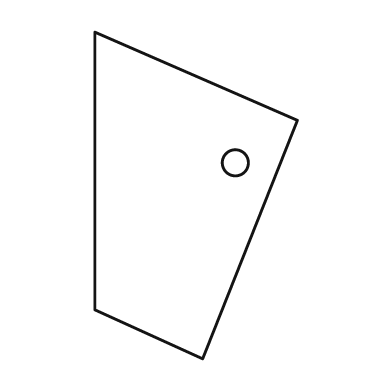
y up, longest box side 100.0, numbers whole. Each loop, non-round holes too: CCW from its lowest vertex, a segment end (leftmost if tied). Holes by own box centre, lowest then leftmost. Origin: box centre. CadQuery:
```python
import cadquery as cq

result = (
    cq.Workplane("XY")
    .moveTo(2.0, -50.0)
    .lineTo(31.0, 23.0)
    .lineTo(-31.0, 50.0)
    .lineTo(-31.0, -35.0)
    .close()
    .moveTo(12.0, 10.0)
    .circle(4.0)
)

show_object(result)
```